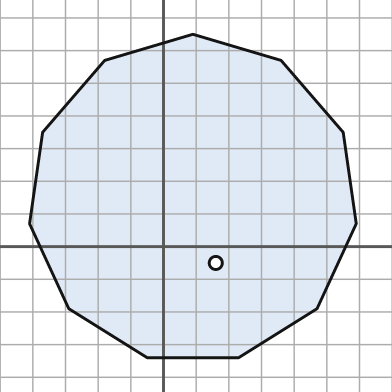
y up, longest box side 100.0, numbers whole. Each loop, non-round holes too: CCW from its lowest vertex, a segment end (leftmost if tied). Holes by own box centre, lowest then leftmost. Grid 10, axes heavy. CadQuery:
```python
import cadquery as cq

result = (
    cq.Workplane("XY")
    .moveTo(-5.0, -34.0)
    .lineTo(23.0, -34.0)
    .lineTo(47.0, -19.0)
    .lineTo(59.0, 7.0)
    .lineTo(55.0, 35.0)
    .lineTo(36.0, 57.0)
    .lineTo(9.0, 65.0)
    .lineTo(-18.0, 57.0)
    .lineTo(-37.0, 35.0)
    .lineTo(-41.0, 7.0)
    .lineTo(-29.0, -19.0)
    .close()
    .moveTo(16.0, -5.0)
    .circle(2.0)
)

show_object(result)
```